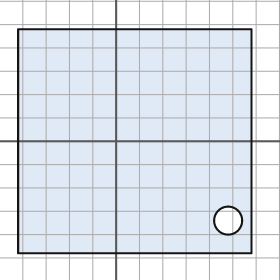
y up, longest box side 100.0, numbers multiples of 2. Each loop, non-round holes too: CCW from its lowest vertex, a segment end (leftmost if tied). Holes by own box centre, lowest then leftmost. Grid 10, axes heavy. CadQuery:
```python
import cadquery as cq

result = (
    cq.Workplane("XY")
    .moveTo(-42.0, -48.0)
    .lineTo(58.0, -48.0)
    .lineTo(58.0, 48.0)
    .lineTo(-42.0, 48.0)
    .close()
    .moveTo(48.0, -34.0)
    .circle(6.0)
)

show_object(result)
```